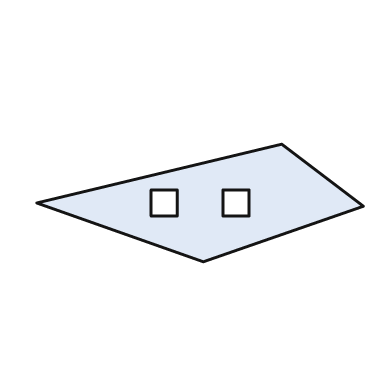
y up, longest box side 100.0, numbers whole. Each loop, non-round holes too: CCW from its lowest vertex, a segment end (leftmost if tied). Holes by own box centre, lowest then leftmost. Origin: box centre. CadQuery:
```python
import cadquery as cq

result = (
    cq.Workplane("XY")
    .moveTo(1.0, -18.0)
    .lineTo(50.0, -1.0)
    .lineTo(25.0, 18.0)
    .lineTo(-50.0, 0.0)
    .close()
    .moveTo(-15.0, -4.0)
    .lineTo(-7.0, -4.0)
    .lineTo(-7.0, 4.0)
    .lineTo(-15.0, 4.0)
    .close()
    .moveTo(7.0, -4.0)
    .lineTo(15.0, -4.0)
    .lineTo(15.0, 4.0)
    .lineTo(7.0, 4.0)
    .close()
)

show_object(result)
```